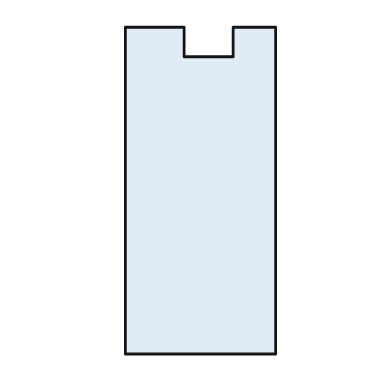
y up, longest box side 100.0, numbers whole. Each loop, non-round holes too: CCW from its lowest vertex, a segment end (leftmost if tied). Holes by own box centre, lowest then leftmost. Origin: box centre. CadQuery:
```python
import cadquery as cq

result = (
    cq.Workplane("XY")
    .moveTo(-23.0, -50.0)
    .lineTo(23.0, -50.0)
    .lineTo(23.0, 50.0)
    .lineTo(10.0, 50.0)
    .lineTo(10.0, 41.0)
    .lineTo(-5.0, 41.0)
    .lineTo(-5.0, 50.0)
    .lineTo(-23.0, 50.0)
    .close()
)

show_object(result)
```